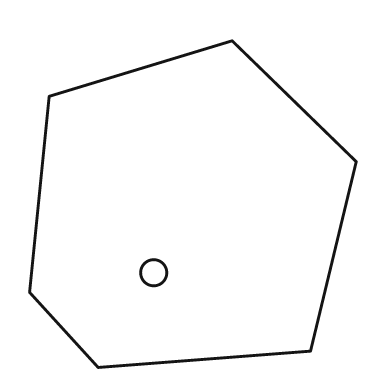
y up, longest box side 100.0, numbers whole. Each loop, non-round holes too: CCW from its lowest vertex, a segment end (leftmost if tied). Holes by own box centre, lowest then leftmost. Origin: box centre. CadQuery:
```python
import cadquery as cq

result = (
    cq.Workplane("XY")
    .moveTo(-29.0, -50.0)
    .lineTo(36.0, -45.0)
    .lineTo(50.0, 13.0)
    .lineTo(12.0, 50.0)
    .lineTo(-44.0, 33.0)
    .lineTo(-50.0, -27.0)
    .close()
    .moveTo(-12.0, -21.0)
    .circle(4.0)
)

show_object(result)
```